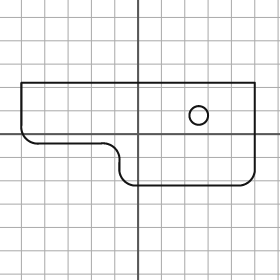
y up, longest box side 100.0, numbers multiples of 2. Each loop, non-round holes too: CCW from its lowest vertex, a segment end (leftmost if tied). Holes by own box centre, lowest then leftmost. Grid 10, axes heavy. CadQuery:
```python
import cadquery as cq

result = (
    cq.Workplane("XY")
    .moveTo(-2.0, -22.0)
    .lineTo(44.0, -22.0)
    .threePointArc((48.0, -20.0), (50.0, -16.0))
    .lineTo(50.0, 22.0)
    .lineTo(-50.0, 22.0)
    .lineTo(-50.0, 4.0)
    .threePointArc((-48.0, -2.0), (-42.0, -4.0))
    .lineTo(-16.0, -4.0)
    .threePointArc((-10.0, -6.0), (-8.0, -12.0))
    .lineTo(-8.0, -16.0)
    .threePointArc((-6.0, -20.0), (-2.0, -22.0))
    .close()
    .moveTo(26.0, 8.0)
    .circle(4.0)
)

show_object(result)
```